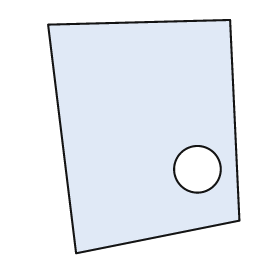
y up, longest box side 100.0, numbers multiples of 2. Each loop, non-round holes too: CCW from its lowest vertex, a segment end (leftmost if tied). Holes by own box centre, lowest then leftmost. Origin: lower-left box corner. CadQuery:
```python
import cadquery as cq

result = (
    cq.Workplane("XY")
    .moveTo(12.0, 0.0)
    .lineTo(82.0, 14.0)
    .lineTo(78.0, 100.0)
    .lineTo(0.0, 98.0)
    .close()
    .moveTo(64.0, 36.0)
    .circle(10.0)
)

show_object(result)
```